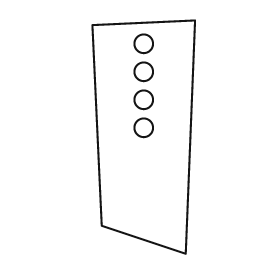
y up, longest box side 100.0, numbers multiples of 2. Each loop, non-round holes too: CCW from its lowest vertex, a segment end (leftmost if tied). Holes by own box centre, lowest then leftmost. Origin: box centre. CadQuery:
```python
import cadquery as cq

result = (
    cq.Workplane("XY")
    .moveTo(18.0, -50.0)
    .lineTo(22.0, 50.0)
    .lineTo(-22.0, 48.0)
    .lineTo(-18.0, -38.0)
    .close()
    .moveTo(0.0, 4.0)
    .circle(4.0)
    .moveTo(0.0, 16.0)
    .circle(4.0)
    .moveTo(0.0, 28.0)
    .circle(4.0)
    .moveTo(0.0, 40.0)
    .circle(4.0)
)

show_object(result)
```